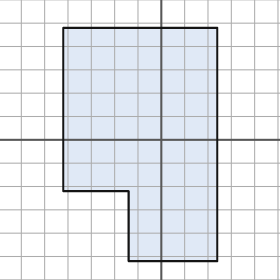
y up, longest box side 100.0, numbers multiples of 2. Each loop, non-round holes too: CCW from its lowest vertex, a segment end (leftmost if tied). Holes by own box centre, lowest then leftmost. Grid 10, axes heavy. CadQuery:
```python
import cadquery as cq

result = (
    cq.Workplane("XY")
    .moveTo(-14.0, -52.0)
    .lineTo(24.0, -52.0)
    .lineTo(24.0, 48.0)
    .lineTo(-42.0, 48.0)
    .lineTo(-42.0, -22.0)
    .lineTo(-14.0, -22.0)
    .close()
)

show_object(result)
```